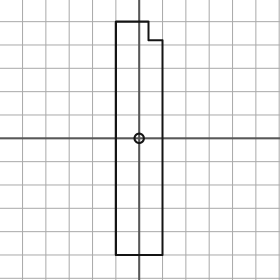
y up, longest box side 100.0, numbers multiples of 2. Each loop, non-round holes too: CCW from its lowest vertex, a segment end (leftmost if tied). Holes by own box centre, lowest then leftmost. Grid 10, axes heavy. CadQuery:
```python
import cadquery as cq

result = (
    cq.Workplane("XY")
    .moveTo(-10.0, -50.0)
    .lineTo(10.0, -50.0)
    .lineTo(10.0, 42.0)
    .lineTo(4.0, 42.0)
    .lineTo(4.0, 50.0)
    .lineTo(-10.0, 50.0)
    .close()
    .moveTo(0.0, 0.0)
    .circle(2.0)
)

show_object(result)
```